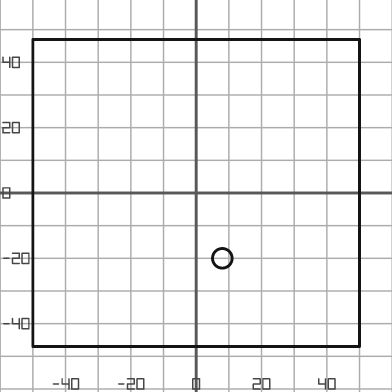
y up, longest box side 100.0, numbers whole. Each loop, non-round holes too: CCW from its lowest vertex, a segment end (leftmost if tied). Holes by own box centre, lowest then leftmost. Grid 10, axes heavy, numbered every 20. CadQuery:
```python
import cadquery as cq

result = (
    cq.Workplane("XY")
    .moveTo(-50.0, -47.0)
    .lineTo(50.0, -47.0)
    .lineTo(50.0, 47.0)
    .lineTo(-50.0, 47.0)
    .close()
    .moveTo(8.0, -20.0)
    .circle(3.0)
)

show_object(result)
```